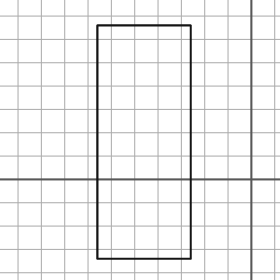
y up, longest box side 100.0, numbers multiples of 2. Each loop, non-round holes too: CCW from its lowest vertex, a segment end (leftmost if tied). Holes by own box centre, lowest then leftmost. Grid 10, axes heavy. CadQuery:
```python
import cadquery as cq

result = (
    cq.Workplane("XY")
    .moveTo(-66.0, -34.0)
    .lineTo(-26.0, -34.0)
    .lineTo(-26.0, 66.0)
    .lineTo(-66.0, 66.0)
    .close()
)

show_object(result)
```